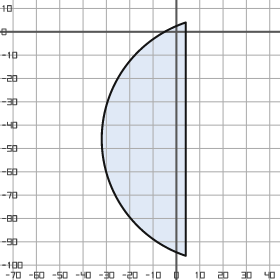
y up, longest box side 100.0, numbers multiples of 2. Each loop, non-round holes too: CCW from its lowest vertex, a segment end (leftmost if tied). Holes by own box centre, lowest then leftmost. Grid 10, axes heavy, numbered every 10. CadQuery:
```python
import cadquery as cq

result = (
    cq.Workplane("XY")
    .moveTo(4.0, -96.0)
    .lineTo(4.0, 4.0)
    .threePointArc((-32.0, -46.0), (4.0, -96.0))
    .close()
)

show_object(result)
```